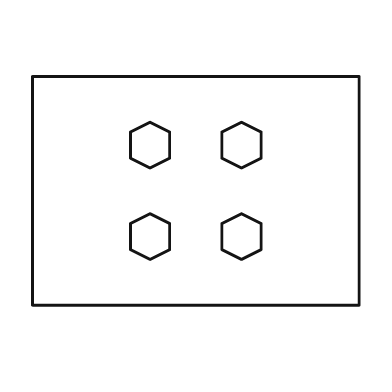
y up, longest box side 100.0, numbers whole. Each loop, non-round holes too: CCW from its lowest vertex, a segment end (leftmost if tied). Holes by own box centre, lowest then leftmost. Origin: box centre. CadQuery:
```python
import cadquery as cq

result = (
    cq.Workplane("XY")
    .moveTo(-50.0, -35.0)
    .lineTo(50.0, -35.0)
    .lineTo(50.0, 35.0)
    .lineTo(-50.0, 35.0)
    .close()
    .moveTo(-14.0, -21.0)
    .lineTo(-8.0, -18.0)
    .lineTo(-8.0, -10.0)
    .lineTo(-14.0, -7.0)
    .lineTo(-20.0, -10.0)
    .lineTo(-20.0, -18.0)
    .close()
    .moveTo(14.0, -21.0)
    .lineTo(20.0, -18.0)
    .lineTo(20.0, -10.0)
    .lineTo(14.0, -7.0)
    .lineTo(8.0, -10.0)
    .lineTo(8.0, -18.0)
    .close()
    .moveTo(-14.0, 7.0)
    .lineTo(-8.0, 10.0)
    .lineTo(-8.0, 18.0)
    .lineTo(-14.0, 21.0)
    .lineTo(-20.0, 18.0)
    .lineTo(-20.0, 10.0)
    .close()
    .moveTo(14.0, 7.0)
    .lineTo(20.0, 10.0)
    .lineTo(20.0, 18.0)
    .lineTo(14.0, 21.0)
    .lineTo(8.0, 18.0)
    .lineTo(8.0, 10.0)
    .close()
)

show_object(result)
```